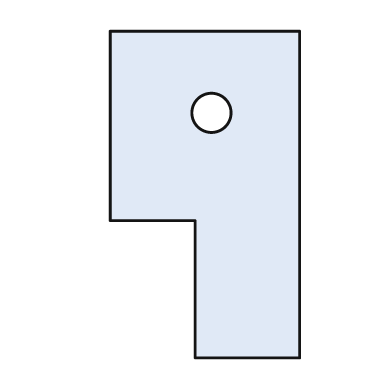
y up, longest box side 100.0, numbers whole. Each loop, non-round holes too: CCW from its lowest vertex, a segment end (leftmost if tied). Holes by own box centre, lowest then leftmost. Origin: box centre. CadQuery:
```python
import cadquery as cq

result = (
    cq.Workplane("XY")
    .moveTo(-3.0, -50.0)
    .lineTo(29.0, -50.0)
    .lineTo(29.0, 50.0)
    .lineTo(-29.0, 50.0)
    .lineTo(-29.0, -8.0)
    .lineTo(-3.0, -8.0)
    .close()
    .moveTo(2.0, 25.0)
    .circle(6.0)
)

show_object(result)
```